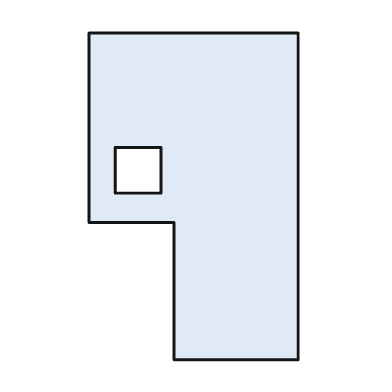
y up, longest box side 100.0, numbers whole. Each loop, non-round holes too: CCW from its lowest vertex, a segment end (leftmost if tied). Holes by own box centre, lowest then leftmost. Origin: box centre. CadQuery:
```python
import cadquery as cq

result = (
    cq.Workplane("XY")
    .moveTo(-6.0, -50.0)
    .lineTo(32.0, -50.0)
    .lineTo(32.0, 50.0)
    .lineTo(-32.0, 50.0)
    .lineTo(-32.0, -8.0)
    .lineTo(-6.0, -8.0)
    .close()
    .moveTo(-24.0, 1.0)
    .lineTo(-10.0, 1.0)
    .lineTo(-10.0, 15.0)
    .lineTo(-24.0, 15.0)
    .close()
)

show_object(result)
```